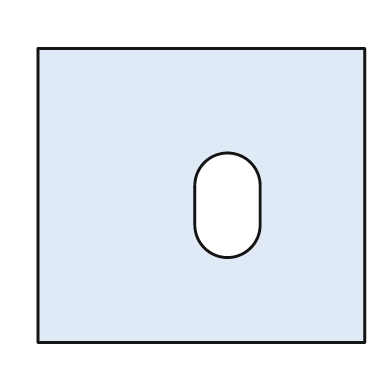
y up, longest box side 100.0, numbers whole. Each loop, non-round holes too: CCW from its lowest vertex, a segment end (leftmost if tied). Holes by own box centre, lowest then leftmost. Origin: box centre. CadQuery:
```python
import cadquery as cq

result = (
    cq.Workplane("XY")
    .moveTo(-50.0, -45.0)
    .lineTo(50.0, -45.0)
    .lineTo(50.0, 45.0)
    .lineTo(-50.0, 45.0)
    .close()
    .moveTo(-2.0, -9.0)
    .threePointArc((8.0, -19.0), (18.0, -9.0))
    .lineTo(18.0, 3.0)
    .threePointArc((8.0, 13.0), (-2.0, 3.0))
    .close()
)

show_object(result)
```